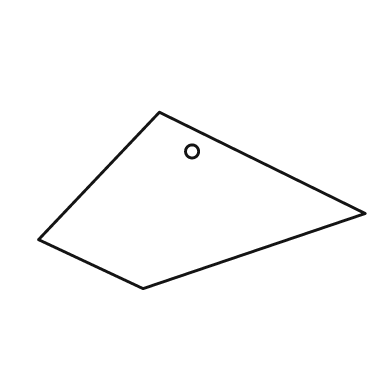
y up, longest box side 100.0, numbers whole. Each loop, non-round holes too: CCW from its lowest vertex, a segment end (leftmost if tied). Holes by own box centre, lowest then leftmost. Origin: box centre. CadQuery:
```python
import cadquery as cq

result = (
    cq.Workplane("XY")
    .moveTo(-18.0, -27.0)
    .lineTo(50.0, -4.0)
    .lineTo(-13.0, 27.0)
    .lineTo(-50.0, -12.0)
    .close()
    .moveTo(-3.0, 15.0)
    .circle(2.0)
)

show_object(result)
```